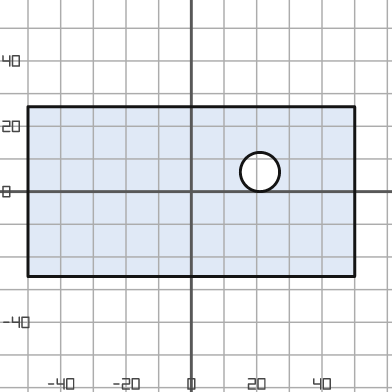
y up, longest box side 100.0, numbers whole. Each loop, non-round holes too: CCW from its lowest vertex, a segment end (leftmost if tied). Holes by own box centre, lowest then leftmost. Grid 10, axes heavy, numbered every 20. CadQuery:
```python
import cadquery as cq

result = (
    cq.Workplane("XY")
    .moveTo(-50.0, -26.0)
    .lineTo(50.0, -26.0)
    .lineTo(50.0, 26.0)
    .lineTo(-50.0, 26.0)
    .close()
    .moveTo(21.0, 6.0)
    .circle(6.0)
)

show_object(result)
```